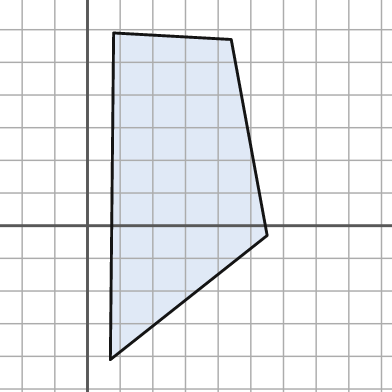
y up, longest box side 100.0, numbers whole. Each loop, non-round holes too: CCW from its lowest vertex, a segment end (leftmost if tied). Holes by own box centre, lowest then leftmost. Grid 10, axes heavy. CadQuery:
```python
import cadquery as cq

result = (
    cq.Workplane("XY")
    .moveTo(7.0, -41.0)
    .lineTo(55.0, -3.0)
    .lineTo(44.0, 57.0)
    .lineTo(8.0, 59.0)
    .close()
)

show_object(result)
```